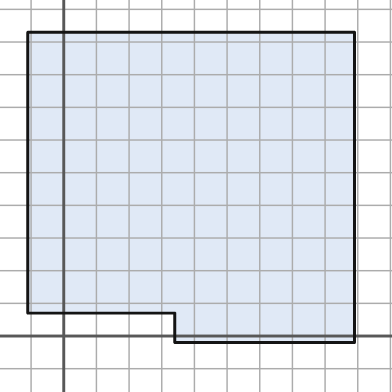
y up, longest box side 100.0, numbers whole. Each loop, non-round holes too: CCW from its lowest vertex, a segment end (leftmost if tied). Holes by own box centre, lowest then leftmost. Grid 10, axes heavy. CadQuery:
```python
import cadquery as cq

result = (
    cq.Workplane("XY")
    .moveTo(34.0, -2.0)
    .lineTo(89.0, -2.0)
    .lineTo(89.0, 93.0)
    .lineTo(-11.0, 93.0)
    .lineTo(-11.0, 7.0)
    .lineTo(34.0, 7.0)
    .close()
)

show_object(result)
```